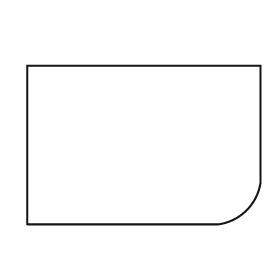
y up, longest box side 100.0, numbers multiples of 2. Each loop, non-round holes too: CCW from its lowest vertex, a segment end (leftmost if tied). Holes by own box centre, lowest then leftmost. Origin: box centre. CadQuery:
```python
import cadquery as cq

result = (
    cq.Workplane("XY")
    .moveTo(-50.0, -34.0)
    .lineTo(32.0, -34.0)
    .threePointArc((44.0, -28.0), (50.0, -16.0))
    .lineTo(50.0, 34.0)
    .lineTo(-50.0, 34.0)
    .close()
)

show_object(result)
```